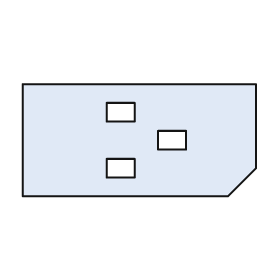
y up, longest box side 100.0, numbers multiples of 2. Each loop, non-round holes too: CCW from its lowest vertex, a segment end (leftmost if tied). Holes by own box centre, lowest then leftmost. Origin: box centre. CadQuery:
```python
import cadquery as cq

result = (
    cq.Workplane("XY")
    .moveTo(-50.0, -24.0)
    .lineTo(38.0, -24.0)
    .lineTo(50.0, -12.0)
    .lineTo(50.0, 24.0)
    .lineTo(-50.0, 24.0)
    .close()
    .moveTo(-14.0, -16.0)
    .lineTo(-2.0, -16.0)
    .lineTo(-2.0, -8.0)
    .lineTo(-14.0, -8.0)
    .close()
    .moveTo(8.0, -4.0)
    .lineTo(20.0, -4.0)
    .lineTo(20.0, 4.0)
    .lineTo(8.0, 4.0)
    .close()
    .moveTo(-14.0, 8.0)
    .lineTo(-2.0, 8.0)
    .lineTo(-2.0, 16.0)
    .lineTo(-14.0, 16.0)
    .close()
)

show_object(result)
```